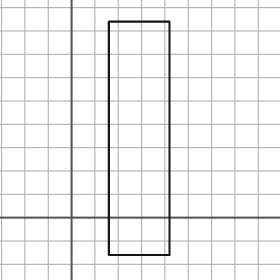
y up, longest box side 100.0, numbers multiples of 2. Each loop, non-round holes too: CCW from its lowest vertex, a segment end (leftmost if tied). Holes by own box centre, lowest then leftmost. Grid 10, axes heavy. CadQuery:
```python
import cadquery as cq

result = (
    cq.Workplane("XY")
    .moveTo(16.0, -16.0)
    .lineTo(42.0, -16.0)
    .lineTo(42.0, 84.0)
    .lineTo(16.0, 84.0)
    .close()
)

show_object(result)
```